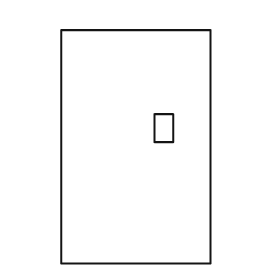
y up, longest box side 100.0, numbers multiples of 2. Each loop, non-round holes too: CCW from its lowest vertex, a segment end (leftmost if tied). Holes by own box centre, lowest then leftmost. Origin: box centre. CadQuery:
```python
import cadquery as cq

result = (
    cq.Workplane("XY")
    .moveTo(-32.0, -50.0)
    .lineTo(32.0, -50.0)
    .lineTo(32.0, 50.0)
    .lineTo(-32.0, 50.0)
    .close()
    .moveTo(8.0, 2.0)
    .lineTo(16.0, 2.0)
    .lineTo(16.0, 14.0)
    .lineTo(8.0, 14.0)
    .close()
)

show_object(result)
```